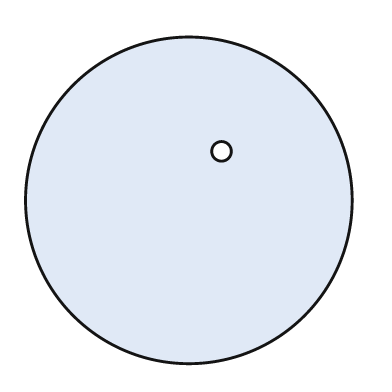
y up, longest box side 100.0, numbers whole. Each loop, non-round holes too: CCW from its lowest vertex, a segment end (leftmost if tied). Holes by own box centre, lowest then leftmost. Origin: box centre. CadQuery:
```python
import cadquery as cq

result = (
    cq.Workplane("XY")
    .moveTo(0.0, 0.0)
    .circle(50.0)
    .moveTo(10.0, 15.0)
    .circle(3.0)
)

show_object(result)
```